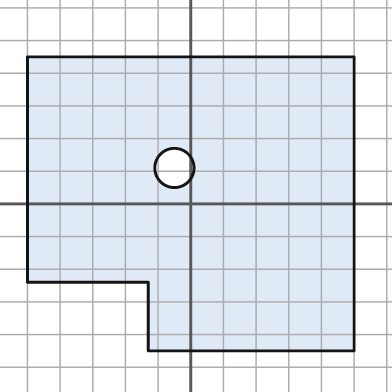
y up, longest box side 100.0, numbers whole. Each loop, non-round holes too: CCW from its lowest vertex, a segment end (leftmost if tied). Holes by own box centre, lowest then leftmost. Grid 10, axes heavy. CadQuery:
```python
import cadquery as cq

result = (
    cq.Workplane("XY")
    .moveTo(-13.0, -45.0)
    .lineTo(50.0, -45.0)
    .lineTo(50.0, 45.0)
    .lineTo(-50.0, 45.0)
    .lineTo(-50.0, -24.0)
    .lineTo(-13.0, -24.0)
    .close()
    .moveTo(-5.0, 11.0)
    .circle(6.0)
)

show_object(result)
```